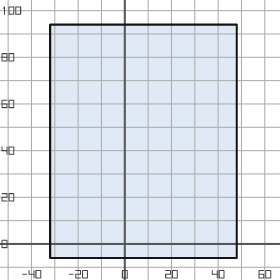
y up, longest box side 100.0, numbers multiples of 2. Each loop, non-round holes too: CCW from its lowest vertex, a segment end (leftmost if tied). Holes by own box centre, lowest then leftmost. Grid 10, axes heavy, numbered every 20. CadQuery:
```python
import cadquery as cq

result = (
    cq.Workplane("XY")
    .moveTo(-32.0, -6.0)
    .lineTo(48.0, -6.0)
    .lineTo(48.0, 94.0)
    .lineTo(-32.0, 94.0)
    .close()
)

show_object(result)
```